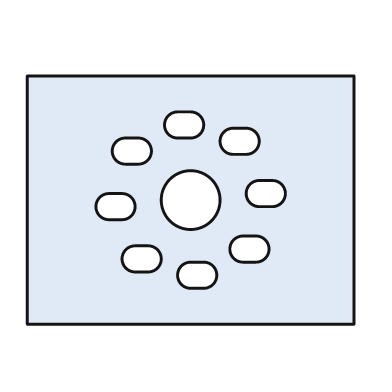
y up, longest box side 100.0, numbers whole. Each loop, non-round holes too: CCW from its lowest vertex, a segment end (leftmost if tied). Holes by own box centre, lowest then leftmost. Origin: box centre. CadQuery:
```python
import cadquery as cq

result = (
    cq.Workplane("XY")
    .moveTo(-50.0, -38.0)
    .lineTo(50.0, -38.0)
    .lineTo(50.0, 38.0)
    .lineTo(-50.0, 38.0)
    .close()
    .moveTo(0.0, -27.0)
    .lineTo(4.0, -27.0)
    .threePointArc((8.0, -23.0), (4.0, -19.0))
    .lineTo(0.0, -19.0)
    .threePointArc((-4.0, -23.0), (0.0, -27.0))
    .close()
    .moveTo(-17.0, -22.0)
    .lineTo(-13.0, -22.0)
    .threePointArc((-9.0, -18.0), (-13.0, -14.0))
    .lineTo(-17.0, -14.0)
    .threePointArc((-21.0, -18.0), (-17.0, -22.0))
    .close()
    .moveTo(16.0, -19.0)
    .lineTo(20.0, -19.0)
    .threePointArc((24.0, -15.0), (20.0, -11.0))
    .lineTo(16.0, -11.0)
    .threePointArc((12.0, -15.0), (16.0, -19.0))
    .close()
    .moveTo(-25.0, -6.0)
    .lineTo(-21.0, -6.0)
    .threePointArc((-17.0, -2.0), (-21.0, 2.0))
    .lineTo(-25.0, 2.0)
    .threePointArc((-29.0, -2.0), (-25.0, -6.0))
    .close()
    .moveTo(0.0, 0.0)
    .circle(9.0)
    .moveTo(21.0, -2.0)
    .lineTo(25.0, -2.0)
    .threePointArc((29.0, 2.0), (25.0, 6.0))
    .lineTo(21.0, 6.0)
    .threePointArc((17.0, 2.0), (21.0, -2.0))
    .close()
    .moveTo(-20.0, 11.0)
    .lineTo(-16.0, 11.0)
    .threePointArc((-12.0, 15.0), (-16.0, 19.0))
    .lineTo(-20.0, 19.0)
    .threePointArc((-24.0, 15.0), (-20.0, 11.0))
    .close()
    .moveTo(13.0, 14.0)
    .lineTo(17.0, 14.0)
    .threePointArc((21.0, 18.0), (17.0, 22.0))
    .lineTo(13.0, 22.0)
    .threePointArc((9.0, 18.0), (13.0, 14.0))
    .close()
    .moveTo(-4.0, 19.0)
    .lineTo(0.0, 19.0)
    .threePointArc((4.0, 23.0), (0.0, 27.0))
    .lineTo(-4.0, 27.0)
    .threePointArc((-8.0, 23.0), (-4.0, 19.0))
    .close()
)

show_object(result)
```